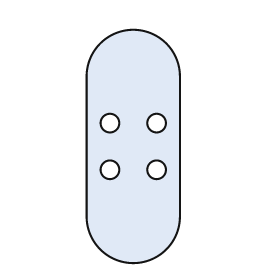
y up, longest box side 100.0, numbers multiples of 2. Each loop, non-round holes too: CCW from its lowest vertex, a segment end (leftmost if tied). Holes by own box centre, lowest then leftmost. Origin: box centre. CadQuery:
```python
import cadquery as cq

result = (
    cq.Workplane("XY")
    .moveTo(-20.0, -30.0)
    .threePointArc((0.0, -50.0), (20.0, -30.0))
    .lineTo(20.0, 30.0)
    .threePointArc((0.0, 50.0), (-20.0, 30.0))
    .close()
    .moveTo(-10.0, -10.0)
    .circle(4.0)
    .moveTo(10.0, -10.0)
    .circle(4.0)
    .moveTo(-10.0, 10.0)
    .circle(4.0)
    .moveTo(10.0, 10.0)
    .circle(4.0)
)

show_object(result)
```